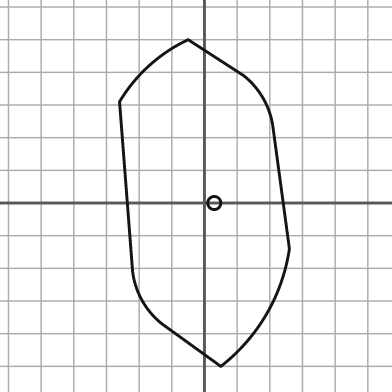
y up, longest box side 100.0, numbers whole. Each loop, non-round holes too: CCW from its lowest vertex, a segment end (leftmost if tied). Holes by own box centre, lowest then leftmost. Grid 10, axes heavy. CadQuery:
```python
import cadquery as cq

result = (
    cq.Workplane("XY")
    .moveTo(5.0, -50.0)
    .threePointArc((19.0, -34.0), (26.0, -14.0))
    .lineTo(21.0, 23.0)
    .threePointArc((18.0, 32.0), (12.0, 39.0))
    .lineTo(-5.0, 50.0)
    .threePointArc((-17.0, 42.0), (-26.0, 31.0))
    .lineTo(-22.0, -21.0)
    .threePointArc((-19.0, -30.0), (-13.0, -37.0))
    .close()
    .moveTo(3.0, 0.0)
    .circle(2.0)
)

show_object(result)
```